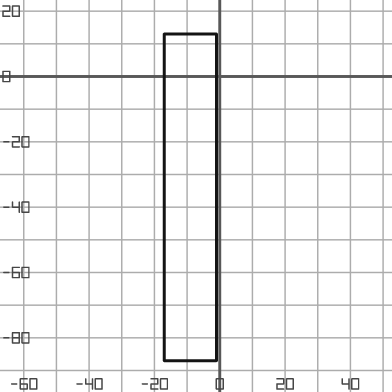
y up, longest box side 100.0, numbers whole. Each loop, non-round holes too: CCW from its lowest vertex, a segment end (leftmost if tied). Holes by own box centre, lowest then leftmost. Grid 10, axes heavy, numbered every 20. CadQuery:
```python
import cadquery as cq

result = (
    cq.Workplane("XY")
    .moveTo(-17.0, -87.0)
    .lineTo(-1.0, -87.0)
    .lineTo(-1.0, 13.0)
    .lineTo(-17.0, 13.0)
    .close()
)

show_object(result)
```